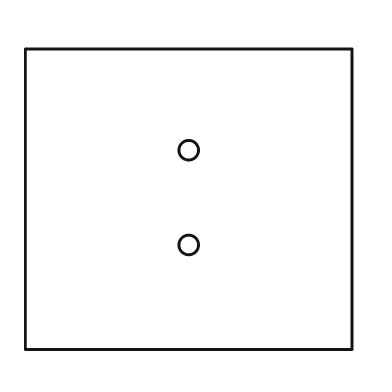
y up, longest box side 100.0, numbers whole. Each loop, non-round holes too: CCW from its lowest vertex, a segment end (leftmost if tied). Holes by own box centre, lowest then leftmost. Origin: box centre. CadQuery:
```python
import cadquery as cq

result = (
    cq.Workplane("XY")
    .moveTo(-50.0, -46.0)
    .lineTo(50.0, -46.0)
    .lineTo(50.0, 46.0)
    .lineTo(-50.0, 46.0)
    .close()
    .moveTo(0.0, -14.0)
    .circle(3.0)
    .moveTo(0.0, 15.0)
    .circle(3.0)
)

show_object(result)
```